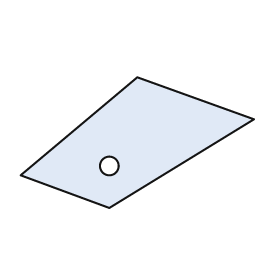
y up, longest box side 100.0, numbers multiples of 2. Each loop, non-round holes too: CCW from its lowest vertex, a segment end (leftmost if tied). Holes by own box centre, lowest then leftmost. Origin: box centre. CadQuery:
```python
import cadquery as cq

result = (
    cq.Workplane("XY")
    .moveTo(-12.0, -28.0)
    .lineTo(50.0, 10.0)
    .lineTo(0.0, 28.0)
    .lineTo(-50.0, -14.0)
    .close()
    .moveTo(-12.0, -10.0)
    .circle(4.0)
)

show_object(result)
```